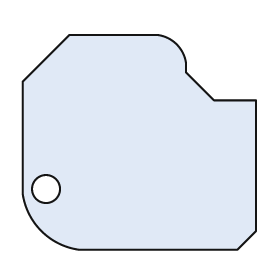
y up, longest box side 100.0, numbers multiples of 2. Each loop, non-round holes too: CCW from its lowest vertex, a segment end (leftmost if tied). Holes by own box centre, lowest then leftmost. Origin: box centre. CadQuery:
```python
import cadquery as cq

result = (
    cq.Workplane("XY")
    .moveTo(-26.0, -46.0)
    .lineTo(42.0, -46.0)
    .lineTo(50.0, -38.0)
    .lineTo(50.0, 18.0)
    .lineTo(32.0, 18.0)
    .lineTo(20.0, 30.0)
    .lineTo(20.0, 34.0)
    .threePointArc((16.0, 42.0), (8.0, 46.0))
    .lineTo(-30.0, 46.0)
    .lineTo(-50.0, 26.0)
    .lineTo(-50.0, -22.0)
    .threePointArc((-42.0, -38.0), (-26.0, -46.0))
    .close()
    .moveTo(-40.0, -20.0)
    .circle(6.0)
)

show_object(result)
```